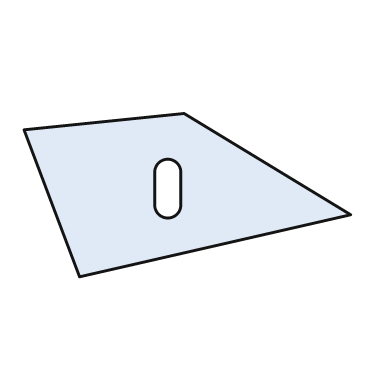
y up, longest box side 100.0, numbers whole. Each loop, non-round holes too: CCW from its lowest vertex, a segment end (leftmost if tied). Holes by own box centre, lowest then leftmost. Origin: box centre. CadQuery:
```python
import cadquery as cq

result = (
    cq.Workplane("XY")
    .moveTo(-33.0, -25.0)
    .lineTo(50.0, -6.0)
    .lineTo(-1.0, 25.0)
    .lineTo(-50.0, 20.0)
    .close()
    .moveTo(-10.0, -3.0)
    .threePointArc((-6.0, -7.0), (-2.0, -3.0))
    .lineTo(-2.0, 7.0)
    .threePointArc((-6.0, 11.0), (-10.0, 7.0))
    .close()
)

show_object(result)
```